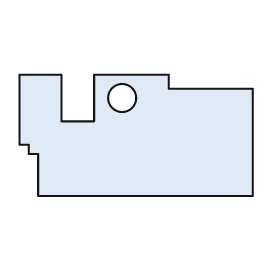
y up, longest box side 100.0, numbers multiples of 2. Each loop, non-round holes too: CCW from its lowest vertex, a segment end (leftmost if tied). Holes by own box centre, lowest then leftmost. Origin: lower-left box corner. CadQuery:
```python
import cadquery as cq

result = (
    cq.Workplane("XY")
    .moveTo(8.0, 0.0)
    .lineTo(100.0, 0.0)
    .lineTo(100.0, 46.0)
    .lineTo(64.0, 46.0)
    .lineTo(64.0, 52.0)
    .lineTo(32.0, 52.0)
    .lineTo(32.0, 32.0)
    .lineTo(18.0, 32.0)
    .lineTo(18.0, 52.0)
    .lineTo(0.0, 52.0)
    .lineTo(0.0, 22.0)
    .lineTo(4.0, 22.0)
    .lineTo(4.0, 18.0)
    .lineTo(8.0, 18.0)
    .close()
    .moveTo(44.0, 42.0)
    .circle(6.0)
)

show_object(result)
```